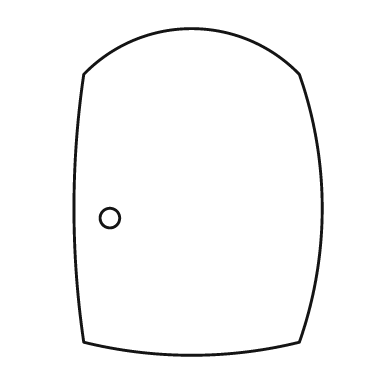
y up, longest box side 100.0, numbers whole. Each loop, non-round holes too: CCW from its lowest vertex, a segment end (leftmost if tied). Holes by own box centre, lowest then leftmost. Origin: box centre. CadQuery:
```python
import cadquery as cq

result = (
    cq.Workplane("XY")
    .moveTo(-35.0, -46.0)
    .threePointArc((-2.0, -50.0), (31.0, -46.0))
    .threePointArc((38.0, -5.0), (31.0, 36.0))
    .threePointArc((-2.0, 50.0), (-35.0, 36.0))
    .threePointArc((-38.0, -5.0), (-35.0, -46.0))
    .close()
    .moveTo(-27.0, -8.0)
    .circle(3.0)
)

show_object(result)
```